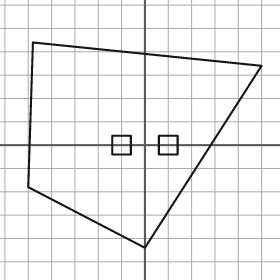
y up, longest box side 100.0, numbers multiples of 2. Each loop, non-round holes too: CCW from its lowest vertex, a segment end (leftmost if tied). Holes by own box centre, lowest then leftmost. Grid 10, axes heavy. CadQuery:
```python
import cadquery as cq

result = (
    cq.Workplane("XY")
    .moveTo(0.0, -44.0)
    .lineTo(50.0, 34.0)
    .lineTo(-48.0, 44.0)
    .lineTo(-50.0, -18.0)
    .close()
    .moveTo(-14.0, -4.0)
    .lineTo(-6.0, -4.0)
    .lineTo(-6.0, 4.0)
    .lineTo(-14.0, 4.0)
    .close()
    .moveTo(6.0, -4.0)
    .lineTo(14.0, -4.0)
    .lineTo(14.0, 4.0)
    .lineTo(6.0, 4.0)
    .close()
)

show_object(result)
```